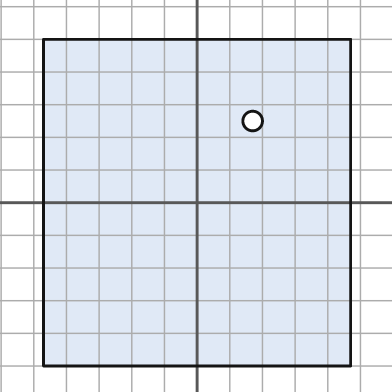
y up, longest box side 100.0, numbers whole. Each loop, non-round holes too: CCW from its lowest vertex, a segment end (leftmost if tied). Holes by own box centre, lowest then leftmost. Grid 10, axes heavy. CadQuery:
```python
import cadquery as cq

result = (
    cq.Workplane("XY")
    .moveTo(-47.0, -50.0)
    .lineTo(47.0, -50.0)
    .lineTo(47.0, 50.0)
    .lineTo(-47.0, 50.0)
    .close()
    .moveTo(17.0, 25.0)
    .circle(3.0)
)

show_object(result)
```